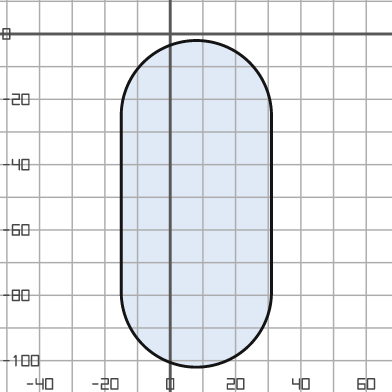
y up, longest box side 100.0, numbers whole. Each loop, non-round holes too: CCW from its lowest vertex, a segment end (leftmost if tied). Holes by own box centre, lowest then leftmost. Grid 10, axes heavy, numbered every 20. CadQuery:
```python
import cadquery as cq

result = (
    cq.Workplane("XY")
    .moveTo(-15.0, -79.0)
    .threePointArc((8.0, -102.0), (31.0, -79.0))
    .lineTo(31.0, -25.0)
    .threePointArc((8.0, -2.0), (-15.0, -25.0))
    .close()
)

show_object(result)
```